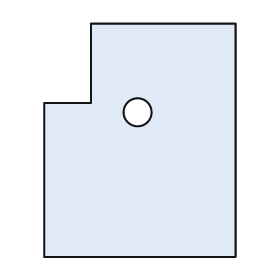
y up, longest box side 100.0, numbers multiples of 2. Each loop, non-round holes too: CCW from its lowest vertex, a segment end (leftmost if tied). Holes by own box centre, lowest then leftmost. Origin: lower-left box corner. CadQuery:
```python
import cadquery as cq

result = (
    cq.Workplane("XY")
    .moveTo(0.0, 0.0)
    .lineTo(82.0, 0.0)
    .lineTo(82.0, 100.0)
    .lineTo(20.0, 100.0)
    .lineTo(20.0, 66.0)
    .lineTo(0.0, 66.0)
    .close()
    .moveTo(40.0, 62.0)
    .circle(6.0)
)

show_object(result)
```